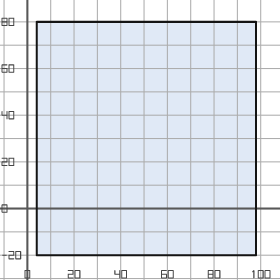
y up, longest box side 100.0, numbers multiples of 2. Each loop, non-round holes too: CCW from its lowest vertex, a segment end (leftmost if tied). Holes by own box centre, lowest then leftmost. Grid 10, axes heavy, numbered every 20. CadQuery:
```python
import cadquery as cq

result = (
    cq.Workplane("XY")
    .moveTo(4.0, -20.0)
    .lineTo(98.0, -20.0)
    .lineTo(98.0, 80.0)
    .lineTo(4.0, 80.0)
    .close()
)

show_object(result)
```